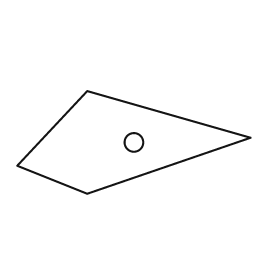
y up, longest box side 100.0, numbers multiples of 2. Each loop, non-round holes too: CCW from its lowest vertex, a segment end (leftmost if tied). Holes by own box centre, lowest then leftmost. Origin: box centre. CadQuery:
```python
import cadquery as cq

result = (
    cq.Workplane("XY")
    .moveTo(-20.0, -22.0)
    .lineTo(50.0, 2.0)
    .lineTo(-20.0, 22.0)
    .lineTo(-50.0, -10.0)
    .close()
    .moveTo(0.0, 0.0)
    .circle(4.0)
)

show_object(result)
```